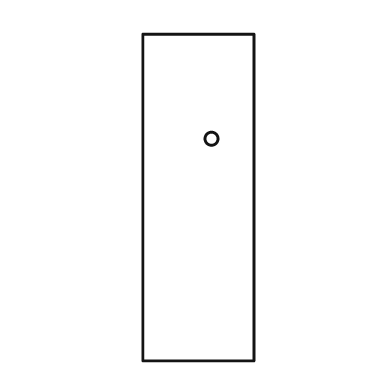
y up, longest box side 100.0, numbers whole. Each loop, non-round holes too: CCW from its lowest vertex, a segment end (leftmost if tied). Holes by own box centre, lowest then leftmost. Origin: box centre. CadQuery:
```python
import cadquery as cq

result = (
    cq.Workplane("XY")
    .moveTo(-17.0, -50.0)
    .lineTo(17.0, -50.0)
    .lineTo(17.0, 50.0)
    .lineTo(-17.0, 50.0)
    .close()
    .moveTo(4.0, 18.0)
    .circle(2.0)
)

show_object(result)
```